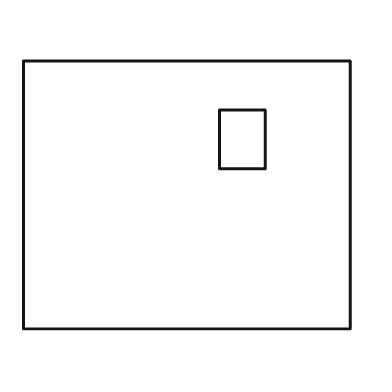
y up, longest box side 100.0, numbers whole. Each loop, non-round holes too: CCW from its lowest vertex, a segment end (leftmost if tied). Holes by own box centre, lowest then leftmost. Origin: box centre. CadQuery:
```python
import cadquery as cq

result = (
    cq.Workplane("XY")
    .moveTo(-50.0, -41.0)
    .lineTo(50.0, -41.0)
    .lineTo(50.0, 41.0)
    .lineTo(-50.0, 41.0)
    .close()
    .moveTo(10.0, 8.0)
    .lineTo(24.0, 8.0)
    .lineTo(24.0, 26.0)
    .lineTo(10.0, 26.0)
    .close()
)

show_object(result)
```